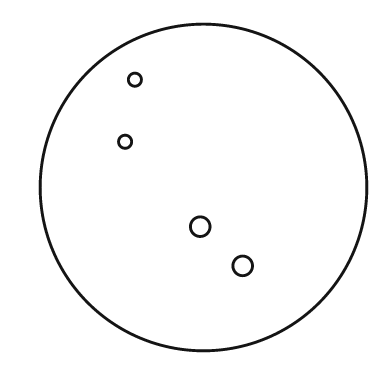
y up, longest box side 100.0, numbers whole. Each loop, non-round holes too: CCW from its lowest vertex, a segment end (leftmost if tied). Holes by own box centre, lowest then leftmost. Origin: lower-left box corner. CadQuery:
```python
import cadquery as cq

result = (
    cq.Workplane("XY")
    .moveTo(50.0, 50.0)
    .circle(50.0)
    .moveTo(62.0, 26.0)
    .circle(3.0)
    .moveTo(49.0, 38.0)
    .circle(3.0)
    .moveTo(26.0, 64.0)
    .circle(2.0)
    .moveTo(29.0, 83.0)
    .circle(2.0)
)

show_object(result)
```